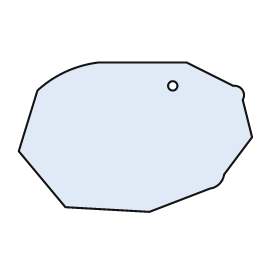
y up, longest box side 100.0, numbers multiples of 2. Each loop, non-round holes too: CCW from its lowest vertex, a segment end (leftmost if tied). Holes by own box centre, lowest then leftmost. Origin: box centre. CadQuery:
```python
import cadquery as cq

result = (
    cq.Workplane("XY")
    .moveTo(6.0, -32.0)
    .lineTo(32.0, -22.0)
    .threePointArc((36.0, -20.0), (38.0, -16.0))
    .lineTo(50.0, 0.0)
    .lineTo(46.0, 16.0)
    .threePointArc((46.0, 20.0), (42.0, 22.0))
    .lineTo(22.0, 32.0)
    .lineTo(-16.0, 32.0)
    .threePointArc((-30.0, 28.0), (-42.0, 20.0))
    .lineTo(-50.0, -6.0)
    .lineTo(-30.0, -30.0)
    .close()
    .moveTo(16.0, 22.0)
    .circle(2.0)
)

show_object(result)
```